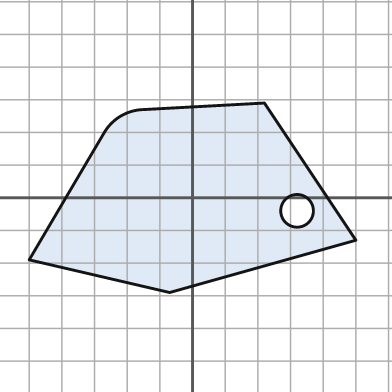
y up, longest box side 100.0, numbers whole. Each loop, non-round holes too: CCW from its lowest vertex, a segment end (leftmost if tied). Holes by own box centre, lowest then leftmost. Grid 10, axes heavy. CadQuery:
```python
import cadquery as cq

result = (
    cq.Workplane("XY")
    .moveTo(-7.0, -29.0)
    .lineTo(50.0, -13.0)
    .lineTo(22.0, 29.0)
    .lineTo(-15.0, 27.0)
    .threePointArc((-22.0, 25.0), (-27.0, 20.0))
    .lineTo(-50.0, -19.0)
    .close()
    .moveTo(32.0, -4.0)
    .circle(5.0)
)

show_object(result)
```